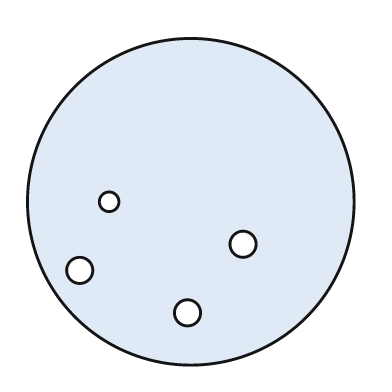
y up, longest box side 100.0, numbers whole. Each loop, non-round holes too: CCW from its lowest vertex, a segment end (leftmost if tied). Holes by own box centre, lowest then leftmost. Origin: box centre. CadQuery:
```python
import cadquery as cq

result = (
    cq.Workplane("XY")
    .moveTo(0.0, 0.0)
    .circle(50.0)
    .moveTo(-1.0, -34.0)
    .circle(4.0)
    .moveTo(-34.0, -21.0)
    .circle(4.0)
    .moveTo(16.0, -13.0)
    .circle(4.0)
    .moveTo(-25.0, 0.0)
    .circle(3.0)
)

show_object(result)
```